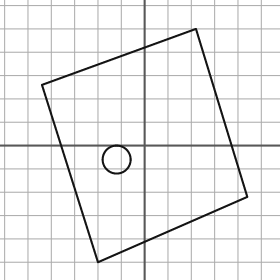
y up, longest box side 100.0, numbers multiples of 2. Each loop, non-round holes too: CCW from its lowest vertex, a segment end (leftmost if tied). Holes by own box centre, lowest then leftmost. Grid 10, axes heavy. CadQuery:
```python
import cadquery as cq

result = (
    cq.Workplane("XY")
    .moveTo(-20.0, -50.0)
    .lineTo(44.0, -22.0)
    .lineTo(22.0, 50.0)
    .lineTo(-44.0, 26.0)
    .close()
    .moveTo(-12.0, -6.0)
    .circle(6.0)
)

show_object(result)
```